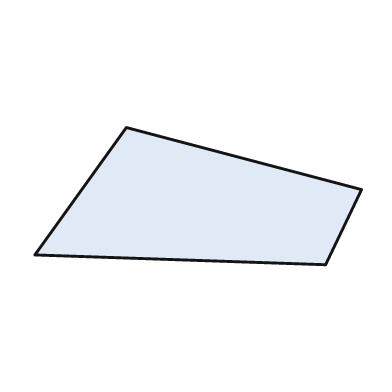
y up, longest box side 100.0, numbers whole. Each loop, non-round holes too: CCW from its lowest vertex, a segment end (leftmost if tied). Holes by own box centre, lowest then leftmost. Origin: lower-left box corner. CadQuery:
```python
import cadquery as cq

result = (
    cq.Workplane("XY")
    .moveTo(89.0, 0.0)
    .lineTo(100.0, 23.0)
    .lineTo(28.0, 42.0)
    .lineTo(0.0, 3.0)
    .close()
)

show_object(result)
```